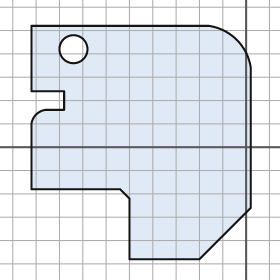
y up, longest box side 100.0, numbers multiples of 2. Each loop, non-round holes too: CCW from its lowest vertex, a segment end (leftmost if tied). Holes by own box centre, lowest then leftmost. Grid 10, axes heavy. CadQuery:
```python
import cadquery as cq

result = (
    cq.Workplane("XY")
    .moveTo(-50.0, -48.0)
    .lineTo(-20.0, -48.0)
    .lineTo(2.0, -26.0)
    .lineTo(2.0, 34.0)
    .threePointArc((-4.0, 46.0), (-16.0, 52.0))
    .lineTo(-92.0, 52.0)
    .lineTo(-92.0, 24.0)
    .lineTo(-78.0, 24.0)
    .lineTo(-78.0, 16.0)
    .lineTo(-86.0, 16.0)
    .threePointArc((-90.0, 14.0), (-92.0, 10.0))
    .lineTo(-92.0, -18.0)
    .lineTo(-54.0, -18.0)
    .lineTo(-50.0, -22.0)
    .close()
    .moveTo(-74.0, 42.0)
    .circle(6.0)
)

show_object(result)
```